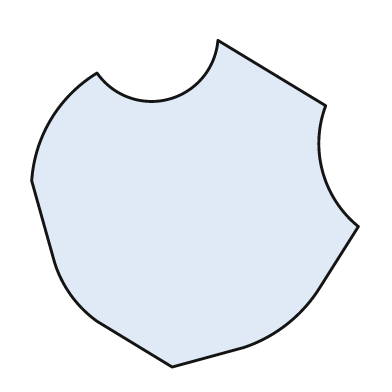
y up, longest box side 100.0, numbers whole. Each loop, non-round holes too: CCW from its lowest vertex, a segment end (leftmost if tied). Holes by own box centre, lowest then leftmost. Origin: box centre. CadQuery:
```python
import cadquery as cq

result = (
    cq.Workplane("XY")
    .moveTo(-7.0, -50.0)
    .lineTo(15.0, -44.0)
    .threePointArc((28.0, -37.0), (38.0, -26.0))
    .lineTo(50.0, -7.0)
    .threePointArc((39.0, 10.0), (40.0, 30.0))
    .lineTo(7.0, 50.0)
    .threePointArc((-8.0, 32.0), (-30.0, 40.0))
    .threePointArc((-44.0, 26.0), (-50.0, 7.0))
    .lineTo(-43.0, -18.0)
    .threePointArc((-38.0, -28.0), (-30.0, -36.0))
    .close()
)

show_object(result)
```